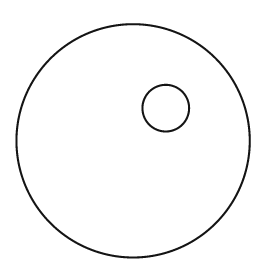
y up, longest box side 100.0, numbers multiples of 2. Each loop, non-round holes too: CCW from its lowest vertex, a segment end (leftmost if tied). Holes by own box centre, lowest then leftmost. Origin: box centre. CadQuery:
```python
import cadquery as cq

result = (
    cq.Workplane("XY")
    .moveTo(0.0, 0.0)
    .circle(50.0)
    .moveTo(14.0, 14.0)
    .circle(10.0)
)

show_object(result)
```